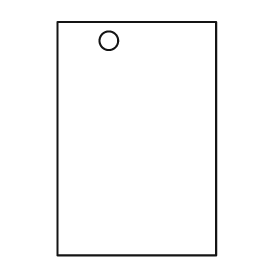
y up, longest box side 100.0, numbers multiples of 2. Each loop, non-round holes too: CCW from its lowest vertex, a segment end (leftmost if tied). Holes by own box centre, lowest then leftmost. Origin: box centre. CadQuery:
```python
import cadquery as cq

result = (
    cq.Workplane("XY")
    .moveTo(-34.0, -50.0)
    .lineTo(34.0, -50.0)
    .lineTo(34.0, 50.0)
    .lineTo(-34.0, 50.0)
    .close()
    .moveTo(-12.0, 42.0)
    .circle(4.0)
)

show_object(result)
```